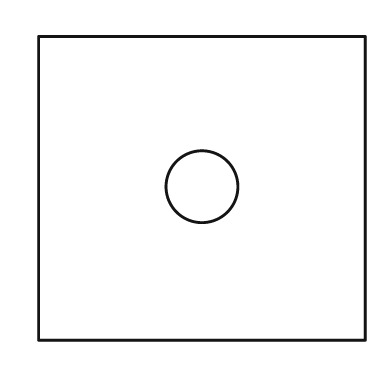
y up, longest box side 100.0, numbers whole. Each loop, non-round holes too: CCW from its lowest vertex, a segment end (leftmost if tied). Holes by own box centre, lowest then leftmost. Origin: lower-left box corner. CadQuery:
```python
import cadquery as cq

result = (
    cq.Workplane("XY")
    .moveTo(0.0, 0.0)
    .lineTo(100.0, 0.0)
    .lineTo(100.0, 93.0)
    .lineTo(0.0, 93.0)
    .close()
    .moveTo(50.0, 47.0)
    .circle(11.0)
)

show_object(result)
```